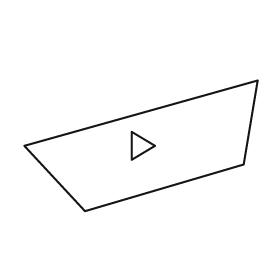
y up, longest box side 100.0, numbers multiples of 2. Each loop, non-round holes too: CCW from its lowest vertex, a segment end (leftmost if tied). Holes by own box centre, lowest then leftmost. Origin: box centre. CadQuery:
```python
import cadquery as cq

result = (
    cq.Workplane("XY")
    .moveTo(-24.0, -28.0)
    .lineTo(44.0, -8.0)
    .lineTo(50.0, 28.0)
    .lineTo(-50.0, 0.0)
    .close()
    .moveTo(-4.0, -6.0)
    .lineTo(6.0, 0.0)
    .lineTo(-4.0, 6.0)
    .close()
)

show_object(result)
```